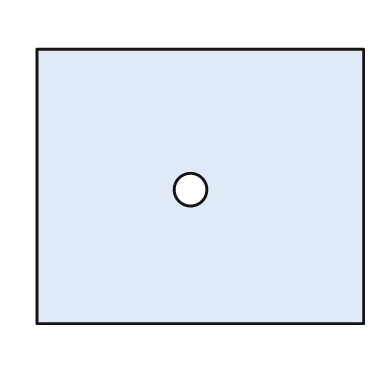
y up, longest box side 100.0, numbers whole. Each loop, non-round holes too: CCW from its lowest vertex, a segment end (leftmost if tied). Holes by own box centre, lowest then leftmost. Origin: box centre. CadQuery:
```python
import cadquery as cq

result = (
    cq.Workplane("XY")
    .moveTo(-50.0, -42.0)
    .lineTo(50.0, -42.0)
    .lineTo(50.0, 42.0)
    .lineTo(-50.0, 42.0)
    .close()
    .moveTo(-3.0, -1.0)
    .circle(5.0)
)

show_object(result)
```